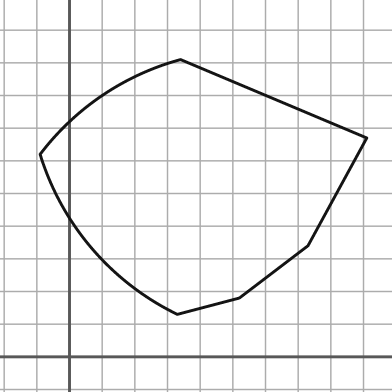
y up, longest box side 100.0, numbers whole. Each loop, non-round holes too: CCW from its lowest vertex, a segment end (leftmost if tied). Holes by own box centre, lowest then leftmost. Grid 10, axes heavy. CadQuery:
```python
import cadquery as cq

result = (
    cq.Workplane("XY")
    .moveTo(33.0, 13.0)
    .lineTo(52.0, 18.0)
    .lineTo(73.0, 34.0)
    .lineTo(91.0, 67.0)
    .lineTo(34.0, 91.0)
    .threePointArc((10.0, 80.0), (-9.0, 62.0))
    .threePointArc((7.0, 33.0), (33.0, 13.0))
    .close()
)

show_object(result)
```